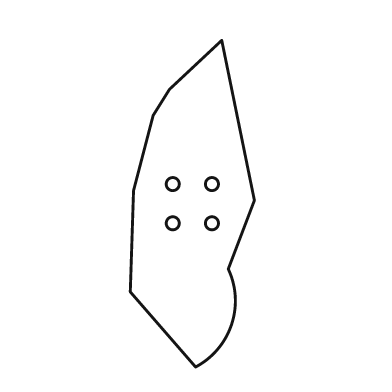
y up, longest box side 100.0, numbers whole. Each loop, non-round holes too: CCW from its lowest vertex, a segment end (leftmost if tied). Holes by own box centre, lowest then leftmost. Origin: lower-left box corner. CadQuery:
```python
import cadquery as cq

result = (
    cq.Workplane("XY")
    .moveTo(20.0, 0.0)
    .threePointArc((31.0, 13.0), (30.0, 30.0))
    .lineTo(38.0, 51.0)
    .lineTo(28.0, 100.0)
    .lineTo(12.0, 85.0)
    .lineTo(7.0, 77.0)
    .lineTo(1.0, 54.0)
    .lineTo(0.0, 23.0)
    .close()
    .moveTo(13.0, 44.0)
    .circle(2.0)
    .moveTo(25.0, 44.0)
    .circle(2.0)
    .moveTo(13.0, 56.0)
    .circle(2.0)
    .moveTo(25.0, 56.0)
    .circle(2.0)
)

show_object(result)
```